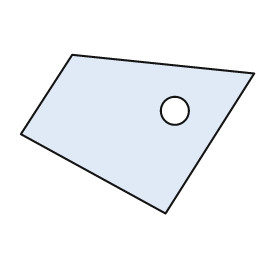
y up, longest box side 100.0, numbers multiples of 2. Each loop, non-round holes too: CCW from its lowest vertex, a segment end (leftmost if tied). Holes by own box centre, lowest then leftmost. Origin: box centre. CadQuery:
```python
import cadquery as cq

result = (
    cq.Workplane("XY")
    .moveTo(12.0, -34.0)
    .lineTo(50.0, 26.0)
    .lineTo(-28.0, 34.0)
    .lineTo(-50.0, 0.0)
    .close()
    .moveTo(16.0, 10.0)
    .circle(6.0)
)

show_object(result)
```